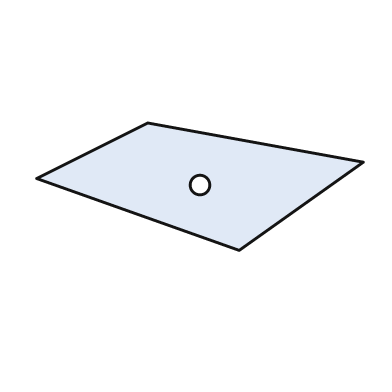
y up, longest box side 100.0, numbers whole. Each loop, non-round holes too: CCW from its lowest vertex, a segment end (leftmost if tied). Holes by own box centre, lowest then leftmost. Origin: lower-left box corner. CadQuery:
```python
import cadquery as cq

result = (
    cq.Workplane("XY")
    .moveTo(62.0, 0.0)
    .lineTo(100.0, 27.0)
    .lineTo(34.0, 39.0)
    .lineTo(0.0, 22.0)
    .close()
    .moveTo(50.0, 20.0)
    .circle(3.0)
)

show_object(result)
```